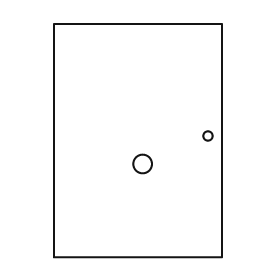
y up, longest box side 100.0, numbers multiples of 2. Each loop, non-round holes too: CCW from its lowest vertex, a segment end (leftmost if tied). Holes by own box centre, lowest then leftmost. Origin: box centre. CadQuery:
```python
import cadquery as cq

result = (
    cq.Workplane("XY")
    .moveTo(-36.0, -50.0)
    .lineTo(36.0, -50.0)
    .lineTo(36.0, 50.0)
    .lineTo(-36.0, 50.0)
    .close()
    .moveTo(2.0, -10.0)
    .circle(4.0)
    .moveTo(30.0, 2.0)
    .circle(2.0)
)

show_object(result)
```